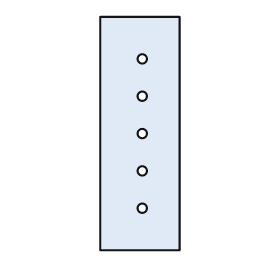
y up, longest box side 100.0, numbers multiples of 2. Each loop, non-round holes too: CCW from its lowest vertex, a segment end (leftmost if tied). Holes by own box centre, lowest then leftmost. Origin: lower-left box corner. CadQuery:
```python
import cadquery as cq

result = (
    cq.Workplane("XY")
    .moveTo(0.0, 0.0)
    .lineTo(34.0, 0.0)
    .lineTo(34.0, 100.0)
    .lineTo(0.0, 100.0)
    .close()
    .moveTo(18.0, 18.0)
    .circle(2.0)
    .moveTo(18.0, 34.0)
    .circle(2.0)
    .moveTo(18.0, 50.0)
    .circle(2.0)
    .moveTo(18.0, 66.0)
    .circle(2.0)
    .moveTo(18.0, 82.0)
    .circle(2.0)
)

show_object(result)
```